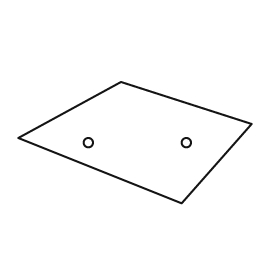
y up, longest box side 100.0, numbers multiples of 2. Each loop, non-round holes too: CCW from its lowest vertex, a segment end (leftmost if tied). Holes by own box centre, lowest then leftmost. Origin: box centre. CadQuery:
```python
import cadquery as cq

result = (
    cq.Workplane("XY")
    .moveTo(20.0, -26.0)
    .lineTo(50.0, 8.0)
    .lineTo(-6.0, 26.0)
    .lineTo(-50.0, 2.0)
    .close()
    .moveTo(-20.0, 0.0)
    .circle(2.0)
    .moveTo(22.0, 0.0)
    .circle(2.0)
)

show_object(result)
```